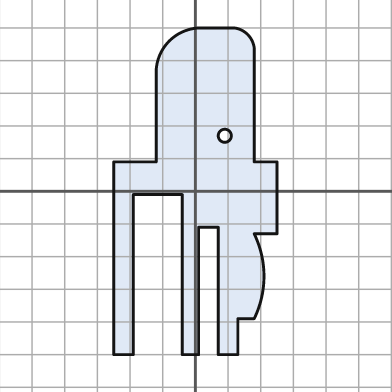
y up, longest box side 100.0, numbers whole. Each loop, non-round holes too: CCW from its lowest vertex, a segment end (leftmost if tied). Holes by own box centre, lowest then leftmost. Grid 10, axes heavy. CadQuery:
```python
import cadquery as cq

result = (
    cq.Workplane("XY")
    .moveTo(-25.0, -50.0)
    .lineTo(-19.0, -50.0)
    .lineTo(-19.0, -1.0)
    .lineTo(-4.0, -1.0)
    .lineTo(-4.0, -50.0)
    .lineTo(1.0, -50.0)
    .lineTo(1.0, -11.0)
    .lineTo(7.0, -11.0)
    .lineTo(7.0, -50.0)
    .lineTo(13.0, -50.0)
    .lineTo(13.0, -39.0)
    .lineTo(18.0, -39.0)
    .threePointArc((21.0, -26.0), (18.0, -13.0))
    .lineTo(25.0, -13.0)
    .lineTo(25.0, 9.0)
    .lineTo(18.0, 9.0)
    .lineTo(18.0, 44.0)
    .threePointArc((16.0, 48.0), (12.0, 50.0))
    .lineTo(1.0, 50.0)
    .threePointArc((-8.0, 46.0), (-12.0, 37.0))
    .lineTo(-12.0, 9.0)
    .lineTo(-25.0, 9.0)
    .close()
    .moveTo(9.0, 17.0)
    .circle(2.0)
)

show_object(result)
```